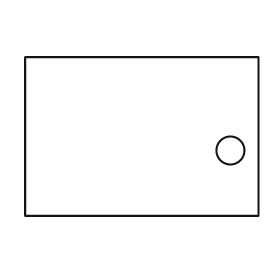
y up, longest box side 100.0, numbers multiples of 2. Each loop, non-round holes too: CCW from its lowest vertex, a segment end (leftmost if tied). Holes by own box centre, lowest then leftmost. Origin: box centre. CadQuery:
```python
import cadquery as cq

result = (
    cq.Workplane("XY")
    .moveTo(-50.0, -34.0)
    .lineTo(50.0, -34.0)
    .lineTo(50.0, 34.0)
    .lineTo(-50.0, 34.0)
    .close()
    .moveTo(38.0, -6.0)
    .circle(6.0)
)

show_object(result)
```